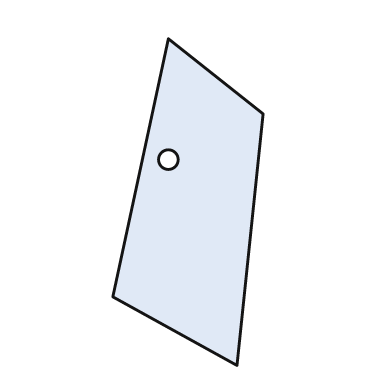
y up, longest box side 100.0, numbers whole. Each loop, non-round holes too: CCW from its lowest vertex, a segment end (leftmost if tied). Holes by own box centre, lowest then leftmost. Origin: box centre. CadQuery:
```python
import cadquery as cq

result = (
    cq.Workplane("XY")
    .moveTo(15.0, -50.0)
    .lineTo(23.0, 27.0)
    .lineTo(-6.0, 50.0)
    .lineTo(-23.0, -29.0)
    .close()
    .moveTo(-6.0, 13.0)
    .circle(3.0)
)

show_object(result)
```